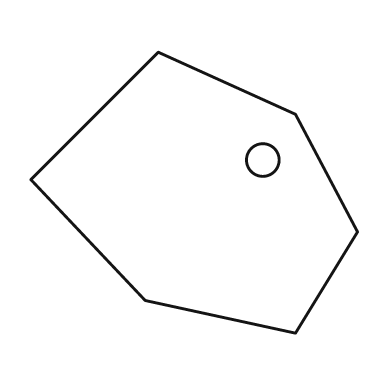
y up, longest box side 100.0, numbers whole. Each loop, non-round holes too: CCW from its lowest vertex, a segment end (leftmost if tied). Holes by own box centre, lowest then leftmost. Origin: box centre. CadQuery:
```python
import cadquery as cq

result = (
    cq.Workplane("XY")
    .moveTo(31.0, -43.0)
    .lineTo(50.0, -12.0)
    .lineTo(31.0, 24.0)
    .lineTo(-11.0, 43.0)
    .lineTo(-50.0, 4.0)
    .lineTo(-15.0, -33.0)
    .close()
    .moveTo(21.0, 10.0)
    .circle(5.0)
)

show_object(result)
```